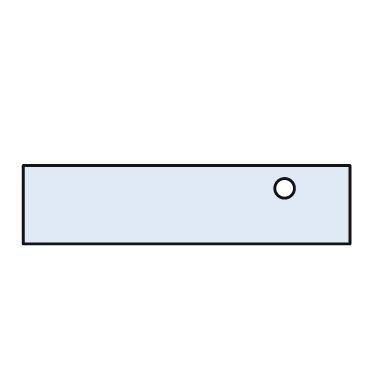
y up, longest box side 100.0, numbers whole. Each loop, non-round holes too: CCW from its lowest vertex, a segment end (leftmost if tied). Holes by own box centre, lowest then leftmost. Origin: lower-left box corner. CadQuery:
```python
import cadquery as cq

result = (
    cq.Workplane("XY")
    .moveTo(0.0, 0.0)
    .lineTo(100.0, 0.0)
    .lineTo(100.0, 24.0)
    .lineTo(0.0, 24.0)
    .close()
    .moveTo(80.0, 17.0)
    .circle(3.0)
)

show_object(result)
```